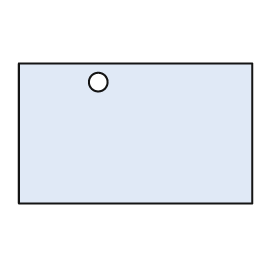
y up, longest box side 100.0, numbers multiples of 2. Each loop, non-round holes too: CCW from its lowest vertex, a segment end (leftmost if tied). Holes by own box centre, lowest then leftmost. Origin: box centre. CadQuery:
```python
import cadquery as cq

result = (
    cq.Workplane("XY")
    .moveTo(-50.0, -30.0)
    .lineTo(50.0, -30.0)
    .lineTo(50.0, 30.0)
    .lineTo(-50.0, 30.0)
    .close()
    .moveTo(-16.0, 22.0)
    .circle(4.0)
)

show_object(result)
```